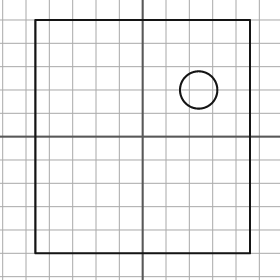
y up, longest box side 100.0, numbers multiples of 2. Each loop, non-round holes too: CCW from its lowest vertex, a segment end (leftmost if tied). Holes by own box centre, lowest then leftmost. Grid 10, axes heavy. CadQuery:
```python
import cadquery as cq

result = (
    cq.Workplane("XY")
    .moveTo(-46.0, -50.0)
    .lineTo(46.0, -50.0)
    .lineTo(46.0, 50.0)
    .lineTo(-46.0, 50.0)
    .close()
    .moveTo(24.0, 20.0)
    .circle(8.0)
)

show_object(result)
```